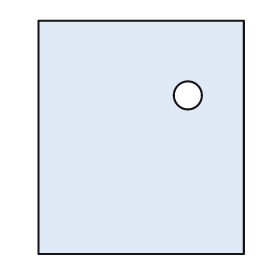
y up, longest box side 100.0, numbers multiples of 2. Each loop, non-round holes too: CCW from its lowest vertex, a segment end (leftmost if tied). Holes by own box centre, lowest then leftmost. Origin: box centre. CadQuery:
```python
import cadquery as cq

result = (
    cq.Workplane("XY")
    .moveTo(-44.0, -50.0)
    .lineTo(44.0, -50.0)
    .lineTo(44.0, 50.0)
    .lineTo(-44.0, 50.0)
    .close()
    .moveTo(20.0, 18.0)
    .circle(6.0)
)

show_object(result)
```